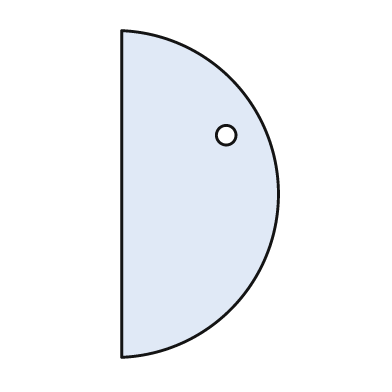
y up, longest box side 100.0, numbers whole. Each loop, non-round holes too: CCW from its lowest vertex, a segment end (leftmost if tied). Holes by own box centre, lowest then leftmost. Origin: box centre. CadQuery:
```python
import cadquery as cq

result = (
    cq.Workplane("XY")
    .moveTo(-24.0, -50.0)
    .threePointArc((24.0, 0.0), (-24.0, 50.0))
    .close()
    .moveTo(8.0, 18.0)
    .circle(3.0)
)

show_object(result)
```